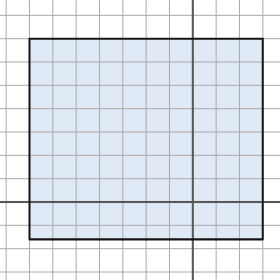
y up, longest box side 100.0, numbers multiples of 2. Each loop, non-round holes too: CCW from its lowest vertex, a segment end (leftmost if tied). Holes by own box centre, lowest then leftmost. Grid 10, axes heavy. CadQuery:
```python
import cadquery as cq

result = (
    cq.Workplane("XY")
    .moveTo(-70.0, -16.0)
    .lineTo(30.0, -16.0)
    .lineTo(30.0, 70.0)
    .lineTo(-70.0, 70.0)
    .close()
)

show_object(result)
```